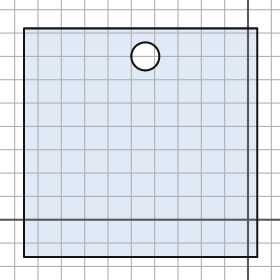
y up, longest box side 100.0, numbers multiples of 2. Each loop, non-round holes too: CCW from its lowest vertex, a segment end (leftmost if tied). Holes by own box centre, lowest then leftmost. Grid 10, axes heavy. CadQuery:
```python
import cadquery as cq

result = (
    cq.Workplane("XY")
    .moveTo(-96.0, -16.0)
    .lineTo(4.0, -16.0)
    .lineTo(4.0, 82.0)
    .lineTo(-96.0, 82.0)
    .close()
    .moveTo(-44.0, 70.0)
    .circle(6.0)
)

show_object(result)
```